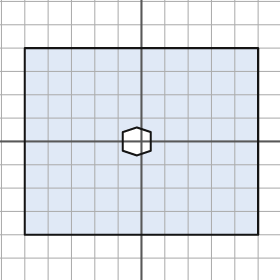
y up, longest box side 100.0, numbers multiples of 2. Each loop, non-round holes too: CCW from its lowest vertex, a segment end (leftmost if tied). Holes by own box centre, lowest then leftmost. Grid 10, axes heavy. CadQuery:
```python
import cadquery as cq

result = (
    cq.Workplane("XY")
    .moveTo(-50.0, -40.0)
    .lineTo(50.0, -40.0)
    .lineTo(50.0, 40.0)
    .lineTo(-50.0, 40.0)
    .close()
    .moveTo(-2.0, -6.0)
    .lineTo(4.0, -4.0)
    .lineTo(4.0, 4.0)
    .lineTo(-2.0, 6.0)
    .lineTo(-8.0, 4.0)
    .lineTo(-8.0, -4.0)
    .close()
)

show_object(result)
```